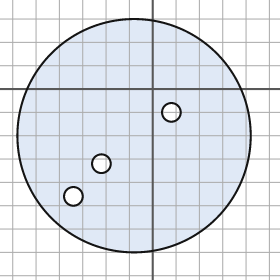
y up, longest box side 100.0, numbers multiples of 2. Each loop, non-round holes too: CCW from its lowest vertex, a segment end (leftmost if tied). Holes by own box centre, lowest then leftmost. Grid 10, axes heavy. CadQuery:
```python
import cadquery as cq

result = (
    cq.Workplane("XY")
    .moveTo(-8.0, -20.0)
    .circle(50.0)
    .moveTo(-34.0, -46.0)
    .circle(4.0)
    .moveTo(-22.0, -32.0)
    .circle(4.0)
    .moveTo(8.0, -10.0)
    .circle(4.0)
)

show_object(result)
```